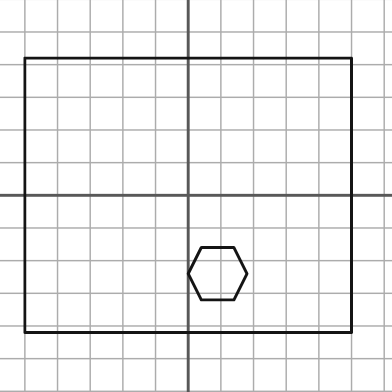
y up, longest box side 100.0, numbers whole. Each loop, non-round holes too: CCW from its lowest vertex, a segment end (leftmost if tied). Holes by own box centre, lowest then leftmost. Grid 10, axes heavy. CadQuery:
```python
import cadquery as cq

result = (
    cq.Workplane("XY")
    .moveTo(-50.0, -42.0)
    .lineTo(50.0, -42.0)
    .lineTo(50.0, 42.0)
    .lineTo(-50.0, 42.0)
    .close()
    .moveTo(4.0, -32.0)
    .lineTo(14.0, -32.0)
    .lineTo(18.0, -24.0)
    .lineTo(14.0, -16.0)
    .lineTo(4.0, -16.0)
    .lineTo(0.0, -24.0)
    .close()
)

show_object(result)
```